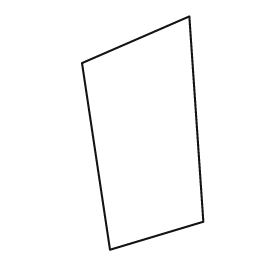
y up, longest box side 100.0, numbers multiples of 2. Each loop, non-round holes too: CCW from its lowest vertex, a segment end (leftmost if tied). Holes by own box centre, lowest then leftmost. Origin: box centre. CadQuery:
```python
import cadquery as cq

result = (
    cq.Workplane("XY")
    .moveTo(-14.0, -50.0)
    .lineTo(26.0, -38.0)
    .lineTo(20.0, 50.0)
    .lineTo(-26.0, 30.0)
    .close()
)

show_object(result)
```